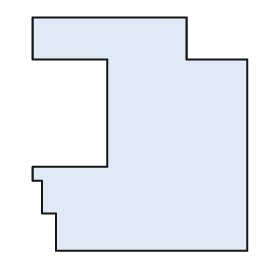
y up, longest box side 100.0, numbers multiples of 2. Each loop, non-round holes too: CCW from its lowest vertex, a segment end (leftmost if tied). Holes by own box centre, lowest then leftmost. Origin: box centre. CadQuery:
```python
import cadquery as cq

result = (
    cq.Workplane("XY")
    .moveTo(-36.0, -50.0)
    .lineTo(46.0, -50.0)
    .lineTo(46.0, 32.0)
    .lineTo(20.0, 32.0)
    .lineTo(20.0, 50.0)
    .lineTo(-46.0, 50.0)
    .lineTo(-46.0, 32.0)
    .lineTo(-14.0, 32.0)
    .lineTo(-14.0, -14.0)
    .lineTo(-46.0, -14.0)
    .lineTo(-46.0, -20.0)
    .lineTo(-42.0, -20.0)
    .lineTo(-42.0, -34.0)
    .lineTo(-36.0, -34.0)
    .close()
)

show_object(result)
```